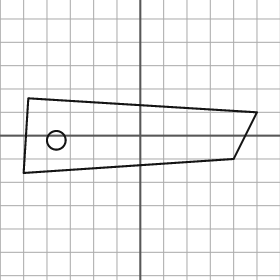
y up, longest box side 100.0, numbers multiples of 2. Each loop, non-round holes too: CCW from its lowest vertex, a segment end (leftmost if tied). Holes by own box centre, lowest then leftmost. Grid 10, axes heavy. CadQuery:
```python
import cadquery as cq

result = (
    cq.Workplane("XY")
    .moveTo(-50.0, -16.0)
    .lineTo(40.0, -10.0)
    .lineTo(50.0, 10.0)
    .lineTo(-48.0, 16.0)
    .close()
    .moveTo(-36.0, -2.0)
    .circle(4.0)
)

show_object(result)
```